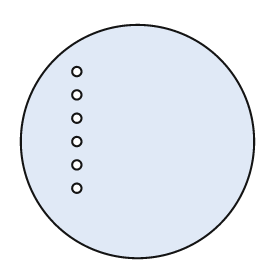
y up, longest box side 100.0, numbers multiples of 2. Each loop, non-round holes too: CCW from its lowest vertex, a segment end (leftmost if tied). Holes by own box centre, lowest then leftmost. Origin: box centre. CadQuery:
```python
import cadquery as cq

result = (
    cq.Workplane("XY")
    .moveTo(0.0, 0.0)
    .circle(50.0)
    .moveTo(-26.0, -20.0)
    .circle(2.0)
    .moveTo(-26.0, -10.0)
    .circle(2.0)
    .moveTo(-26.0, 0.0)
    .circle(2.0)
    .moveTo(-26.0, 10.0)
    .circle(2.0)
    .moveTo(-26.0, 20.0)
    .circle(2.0)
    .moveTo(-26.0, 30.0)
    .circle(2.0)
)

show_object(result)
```